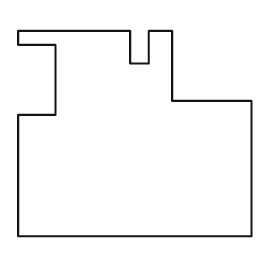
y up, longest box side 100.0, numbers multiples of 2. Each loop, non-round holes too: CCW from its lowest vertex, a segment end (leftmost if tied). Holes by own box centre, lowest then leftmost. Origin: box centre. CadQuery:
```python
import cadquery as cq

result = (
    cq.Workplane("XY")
    .moveTo(-50.0, -44.0)
    .lineTo(50.0, -44.0)
    .lineTo(50.0, 14.0)
    .lineTo(16.0, 14.0)
    .lineTo(16.0, 44.0)
    .lineTo(6.0, 44.0)
    .lineTo(6.0, 30.0)
    .lineTo(-2.0, 30.0)
    .lineTo(-2.0, 44.0)
    .lineTo(-50.0, 44.0)
    .lineTo(-50.0, 38.0)
    .lineTo(-34.0, 38.0)
    .lineTo(-34.0, 8.0)
    .lineTo(-50.0, 8.0)
    .close()
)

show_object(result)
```